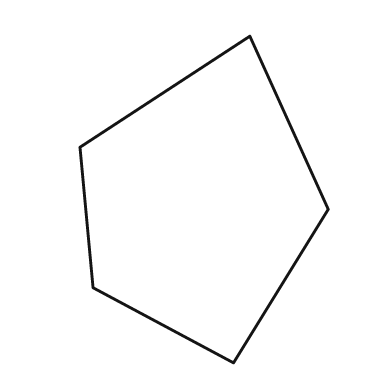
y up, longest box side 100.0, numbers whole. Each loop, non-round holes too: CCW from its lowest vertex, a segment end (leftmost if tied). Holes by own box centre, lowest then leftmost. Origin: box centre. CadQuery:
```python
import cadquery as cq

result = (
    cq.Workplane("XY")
    .moveTo(9.0, -50.0)
    .lineTo(38.0, -3.0)
    .lineTo(14.0, 50.0)
    .lineTo(-38.0, 16.0)
    .lineTo(-34.0, -27.0)
    .close()
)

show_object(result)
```